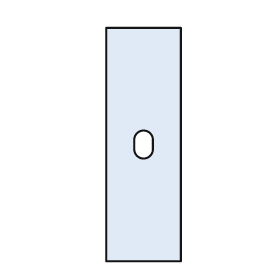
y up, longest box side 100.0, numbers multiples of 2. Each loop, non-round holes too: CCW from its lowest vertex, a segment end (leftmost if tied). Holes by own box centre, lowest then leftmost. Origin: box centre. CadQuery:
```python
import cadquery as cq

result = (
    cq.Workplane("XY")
    .moveTo(-16.0, -50.0)
    .lineTo(16.0, -50.0)
    .lineTo(16.0, 50.0)
    .lineTo(-16.0, 50.0)
    .close()
    .moveTo(-4.0, -2.0)
    .threePointArc((0.0, -6.0), (4.0, -2.0))
    .lineTo(4.0, 2.0)
    .threePointArc((0.0, 6.0), (-4.0, 2.0))
    .close()
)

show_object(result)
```